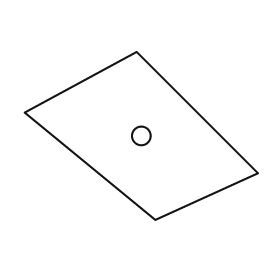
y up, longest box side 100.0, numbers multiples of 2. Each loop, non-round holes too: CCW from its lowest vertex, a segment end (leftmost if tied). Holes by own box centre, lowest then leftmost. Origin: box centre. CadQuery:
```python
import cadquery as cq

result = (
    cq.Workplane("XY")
    .moveTo(6.0, -36.0)
    .lineTo(50.0, -16.0)
    .lineTo(-2.0, 36.0)
    .lineTo(-50.0, 10.0)
    .close()
    .moveTo(0.0, 0.0)
    .circle(4.0)
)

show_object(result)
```